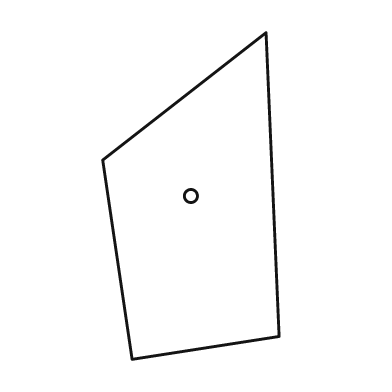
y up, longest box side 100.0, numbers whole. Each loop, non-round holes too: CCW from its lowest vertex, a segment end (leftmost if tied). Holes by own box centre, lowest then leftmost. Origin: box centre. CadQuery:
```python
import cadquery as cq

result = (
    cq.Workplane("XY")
    .moveTo(-18.0, -50.0)
    .lineTo(27.0, -43.0)
    .lineTo(23.0, 50.0)
    .lineTo(-27.0, 11.0)
    .close()
    .moveTo(0.0, 0.0)
    .circle(2.0)
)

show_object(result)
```